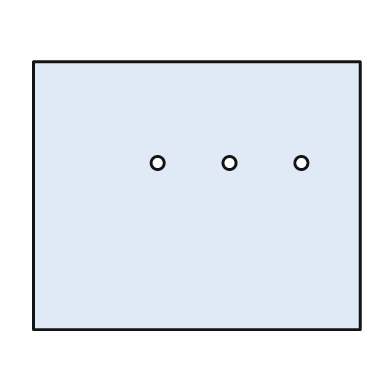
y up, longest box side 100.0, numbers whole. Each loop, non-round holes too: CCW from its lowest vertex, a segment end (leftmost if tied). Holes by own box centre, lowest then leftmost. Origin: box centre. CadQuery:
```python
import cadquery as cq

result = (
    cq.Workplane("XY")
    .moveTo(-50.0, -41.0)
    .lineTo(50.0, -41.0)
    .lineTo(50.0, 41.0)
    .lineTo(-50.0, 41.0)
    .close()
    .moveTo(-12.0, 10.0)
    .circle(2.0)
    .moveTo(10.0, 10.0)
    .circle(2.0)
    .moveTo(32.0, 10.0)
    .circle(2.0)
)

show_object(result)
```